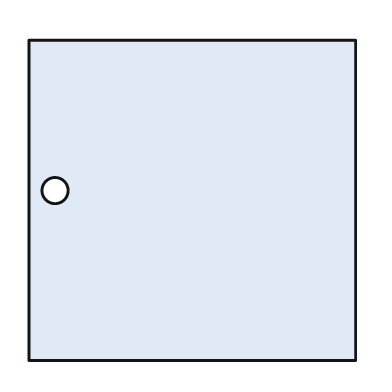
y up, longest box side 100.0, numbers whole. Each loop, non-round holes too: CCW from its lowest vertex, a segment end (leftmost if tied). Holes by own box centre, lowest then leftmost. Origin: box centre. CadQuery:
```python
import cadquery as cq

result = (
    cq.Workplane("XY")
    .moveTo(-50.0, -49.0)
    .lineTo(50.0, -49.0)
    .lineTo(50.0, 49.0)
    .lineTo(-50.0, 49.0)
    .close()
    .moveTo(-42.0, 3.0)
    .circle(4.0)
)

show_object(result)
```